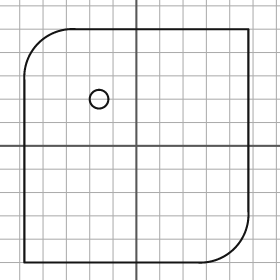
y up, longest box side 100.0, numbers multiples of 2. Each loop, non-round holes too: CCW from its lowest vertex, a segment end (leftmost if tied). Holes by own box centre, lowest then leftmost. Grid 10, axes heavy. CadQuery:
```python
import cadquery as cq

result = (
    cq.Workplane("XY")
    .moveTo(-48.0, -50.0)
    .lineTo(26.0, -50.0)
    .threePointArc((42.0, -44.0), (48.0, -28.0))
    .lineTo(48.0, 50.0)
    .lineTo(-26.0, 50.0)
    .threePointArc((-42.0, 44.0), (-48.0, 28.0))
    .close()
    .moveTo(-16.0, 20.0)
    .circle(4.0)
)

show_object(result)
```